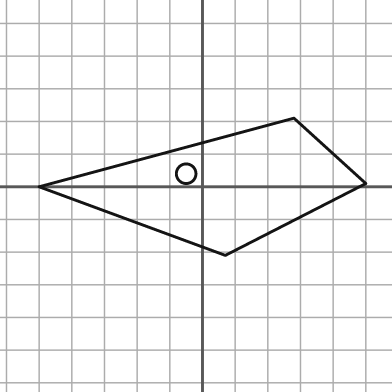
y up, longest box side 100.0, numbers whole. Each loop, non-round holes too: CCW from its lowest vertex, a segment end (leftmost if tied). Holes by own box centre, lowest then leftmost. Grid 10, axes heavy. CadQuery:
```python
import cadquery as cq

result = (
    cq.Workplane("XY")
    .moveTo(7.0, -21.0)
    .lineTo(50.0, 1.0)
    .lineTo(28.0, 21.0)
    .lineTo(-50.0, 0.0)
    .close()
    .moveTo(-5.0, 4.0)
    .circle(3.0)
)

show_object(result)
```